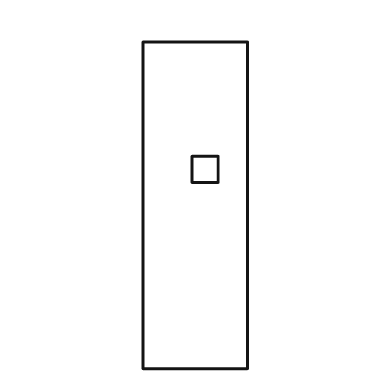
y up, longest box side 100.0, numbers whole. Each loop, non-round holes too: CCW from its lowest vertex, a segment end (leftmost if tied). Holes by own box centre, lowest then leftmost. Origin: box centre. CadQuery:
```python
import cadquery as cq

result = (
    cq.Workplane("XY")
    .moveTo(-16.0, -50.0)
    .lineTo(16.0, -50.0)
    .lineTo(16.0, 50.0)
    .lineTo(-16.0, 50.0)
    .close()
    .moveTo(-1.0, 7.0)
    .lineTo(7.0, 7.0)
    .lineTo(7.0, 15.0)
    .lineTo(-1.0, 15.0)
    .close()
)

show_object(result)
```